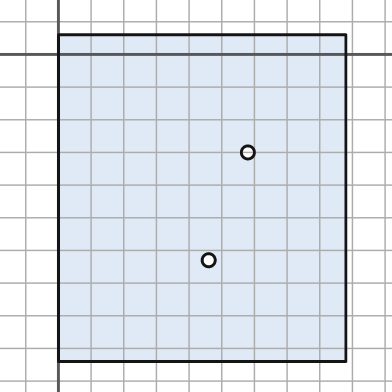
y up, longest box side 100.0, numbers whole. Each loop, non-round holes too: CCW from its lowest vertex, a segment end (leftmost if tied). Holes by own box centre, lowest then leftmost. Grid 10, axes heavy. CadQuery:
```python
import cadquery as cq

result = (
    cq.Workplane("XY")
    .moveTo(0.0, -94.0)
    .lineTo(88.0, -94.0)
    .lineTo(88.0, 6.0)
    .lineTo(0.0, 6.0)
    .close()
    .moveTo(46.0, -63.0)
    .circle(2.0)
    .moveTo(58.0, -30.0)
    .circle(2.0)
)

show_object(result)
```